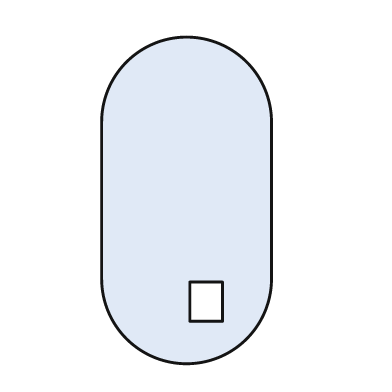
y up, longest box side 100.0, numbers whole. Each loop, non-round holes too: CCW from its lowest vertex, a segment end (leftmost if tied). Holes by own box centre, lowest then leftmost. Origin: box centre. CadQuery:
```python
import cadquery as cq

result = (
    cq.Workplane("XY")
    .moveTo(-26.0, -24.0)
    .threePointArc((0.0, -50.0), (26.0, -24.0))
    .lineTo(26.0, 24.0)
    .threePointArc((0.0, 50.0), (-26.0, 24.0))
    .close()
    .moveTo(1.0, -37.0)
    .lineTo(11.0, -37.0)
    .lineTo(11.0, -25.0)
    .lineTo(1.0, -25.0)
    .close()
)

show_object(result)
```